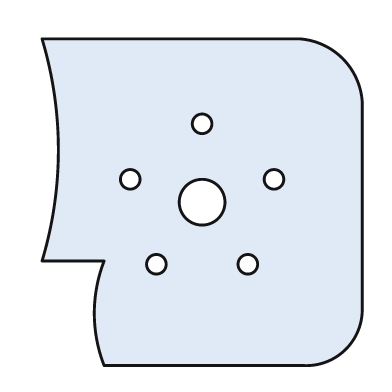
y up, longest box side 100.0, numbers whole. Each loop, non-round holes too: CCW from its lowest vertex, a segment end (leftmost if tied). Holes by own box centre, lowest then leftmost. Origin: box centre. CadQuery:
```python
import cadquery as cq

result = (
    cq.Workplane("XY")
    .moveTo(-30.0, -50.0)
    .lineTo(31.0, -50.0)
    .threePointArc((44.0, -45.0), (49.0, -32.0))
    .lineTo(49.0, 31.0)
    .threePointArc((43.0, 44.0), (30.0, 50.0))
    .lineTo(-49.0, 50.0)
    .threePointArc((-44.0, 16.0), (-49.0, -18.0))
    .lineTo(-30.0, -18.0)
    .threePointArc((-33.0, -34.0), (-30.0, -50.0))
    .close()
    .moveTo(-14.0, -19.0)
    .circle(3.0)
    .moveTo(14.0, -19.0)
    .circle(3.0)
    .moveTo(0.0, 0.0)
    .circle(7.0)
    .moveTo(-22.0, 7.0)
    .circle(3.0)
    .moveTo(22.0, 7.0)
    .circle(3.0)
    .moveTo(0.0, 24.0)
    .circle(3.0)
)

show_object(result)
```